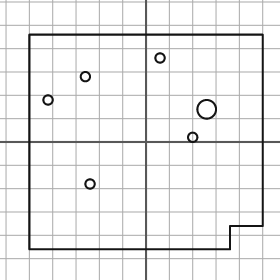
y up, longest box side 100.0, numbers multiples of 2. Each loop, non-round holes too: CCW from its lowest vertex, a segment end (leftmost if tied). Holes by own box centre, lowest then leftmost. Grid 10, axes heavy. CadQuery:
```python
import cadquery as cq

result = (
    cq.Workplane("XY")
    .moveTo(-50.0, -46.0)
    .lineTo(36.0, -46.0)
    .lineTo(36.0, -36.0)
    .lineTo(50.0, -36.0)
    .lineTo(50.0, 46.0)
    .lineTo(-50.0, 46.0)
    .close()
    .moveTo(-24.0, -18.0)
    .circle(2.0)
    .moveTo(20.0, 2.0)
    .circle(2.0)
    .moveTo(26.0, 14.0)
    .circle(4.0)
    .moveTo(-42.0, 18.0)
    .circle(2.0)
    .moveTo(-26.0, 28.0)
    .circle(2.0)
    .moveTo(6.0, 36.0)
    .circle(2.0)
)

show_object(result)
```